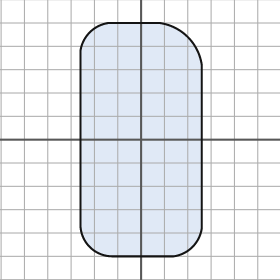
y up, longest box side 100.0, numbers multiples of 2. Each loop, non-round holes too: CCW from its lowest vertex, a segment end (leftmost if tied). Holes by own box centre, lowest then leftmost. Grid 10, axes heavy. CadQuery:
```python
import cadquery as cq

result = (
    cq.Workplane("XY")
    .moveTo(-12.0, -50.0)
    .lineTo(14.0, -50.0)
    .threePointArc((22.0, -46.0), (26.0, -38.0))
    .lineTo(26.0, 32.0)
    .threePointArc((20.0, 44.0), (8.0, 50.0))
    .lineTo(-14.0, 50.0)
    .threePointArc((-22.0, 46.0), (-26.0, 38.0))
    .lineTo(-26.0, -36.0)
    .threePointArc((-22.0, -46.0), (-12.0, -50.0))
    .close()
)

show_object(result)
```